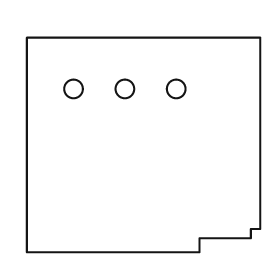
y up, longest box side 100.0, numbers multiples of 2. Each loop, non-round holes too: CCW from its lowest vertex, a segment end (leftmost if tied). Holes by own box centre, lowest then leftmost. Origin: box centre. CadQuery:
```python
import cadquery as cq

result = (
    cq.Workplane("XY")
    .moveTo(-50.0, -46.0)
    .lineTo(24.0, -46.0)
    .lineTo(24.0, -40.0)
    .lineTo(46.0, -40.0)
    .lineTo(46.0, -36.0)
    .lineTo(50.0, -36.0)
    .lineTo(50.0, 46.0)
    .lineTo(-50.0, 46.0)
    .close()
    .moveTo(-30.0, 24.0)
    .circle(4.0)
    .moveTo(-8.0, 24.0)
    .circle(4.0)
    .moveTo(14.0, 24.0)
    .circle(4.0)
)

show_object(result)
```